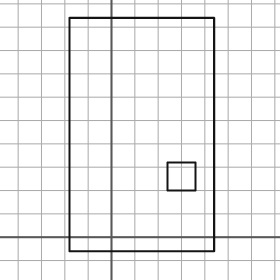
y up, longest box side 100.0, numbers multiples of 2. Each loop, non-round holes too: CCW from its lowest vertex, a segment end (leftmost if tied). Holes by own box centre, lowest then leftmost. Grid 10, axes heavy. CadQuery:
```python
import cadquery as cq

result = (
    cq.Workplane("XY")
    .moveTo(-18.0, -6.0)
    .lineTo(44.0, -6.0)
    .lineTo(44.0, 94.0)
    .lineTo(-18.0, 94.0)
    .close()
    .moveTo(24.0, 20.0)
    .lineTo(36.0, 20.0)
    .lineTo(36.0, 32.0)
    .lineTo(24.0, 32.0)
    .close()
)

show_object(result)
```